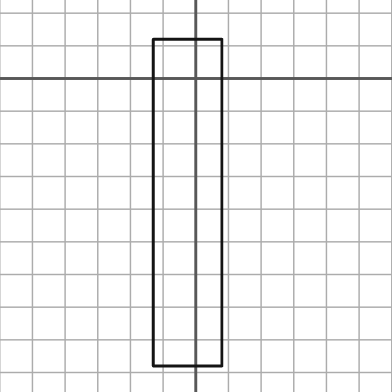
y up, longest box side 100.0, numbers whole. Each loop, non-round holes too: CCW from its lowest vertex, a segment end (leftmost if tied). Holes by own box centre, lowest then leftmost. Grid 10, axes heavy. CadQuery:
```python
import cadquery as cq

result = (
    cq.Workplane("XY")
    .moveTo(-13.0, -88.0)
    .lineTo(8.0, -88.0)
    .lineTo(8.0, 12.0)
    .lineTo(-13.0, 12.0)
    .close()
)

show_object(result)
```